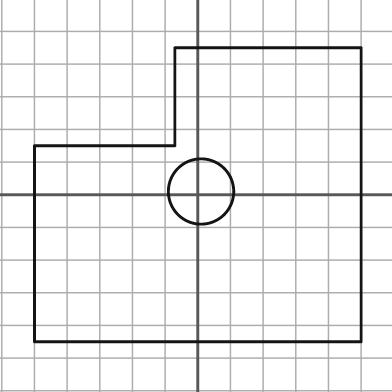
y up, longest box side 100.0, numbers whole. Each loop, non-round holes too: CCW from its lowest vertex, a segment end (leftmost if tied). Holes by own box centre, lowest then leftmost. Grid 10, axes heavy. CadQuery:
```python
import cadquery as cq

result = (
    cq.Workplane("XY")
    .moveTo(-50.0, -45.0)
    .lineTo(50.0, -45.0)
    .lineTo(50.0, 45.0)
    .lineTo(-7.0, 45.0)
    .lineTo(-7.0, 15.0)
    .lineTo(-50.0, 15.0)
    .close()
    .moveTo(1.0, 1.0)
    .circle(10.0)
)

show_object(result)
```